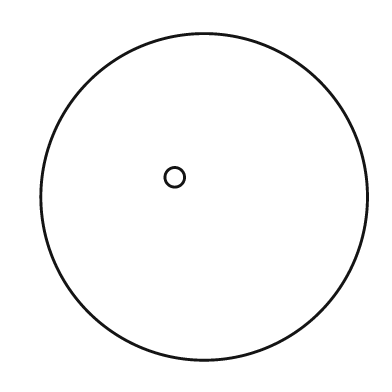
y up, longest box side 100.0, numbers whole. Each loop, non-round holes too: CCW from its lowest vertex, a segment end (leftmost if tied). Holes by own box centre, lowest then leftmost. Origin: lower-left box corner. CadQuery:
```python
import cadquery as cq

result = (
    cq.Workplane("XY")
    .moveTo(50.0, 50.0)
    .circle(50.0)
    .moveTo(41.0, 56.0)
    .circle(3.0)
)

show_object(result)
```